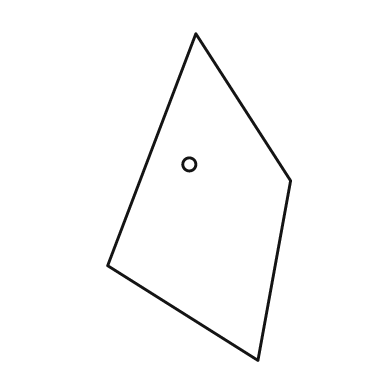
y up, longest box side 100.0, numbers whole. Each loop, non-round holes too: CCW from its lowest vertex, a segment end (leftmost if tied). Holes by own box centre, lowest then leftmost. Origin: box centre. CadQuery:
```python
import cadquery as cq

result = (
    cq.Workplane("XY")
    .moveTo(18.0, -50.0)
    .lineTo(28.0, 5.0)
    .lineTo(-1.0, 50.0)
    .lineTo(-28.0, -21.0)
    .close()
    .moveTo(-3.0, 10.0)
    .circle(2.0)
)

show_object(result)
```